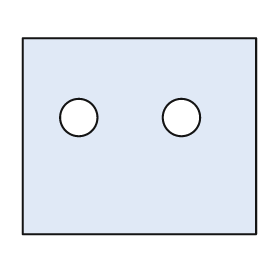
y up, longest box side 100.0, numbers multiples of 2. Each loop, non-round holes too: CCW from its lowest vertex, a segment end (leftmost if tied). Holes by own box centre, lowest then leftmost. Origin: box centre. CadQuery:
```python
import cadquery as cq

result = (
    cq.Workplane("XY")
    .moveTo(-50.0, -42.0)
    .lineTo(50.0, -42.0)
    .lineTo(50.0, 42.0)
    .lineTo(-50.0, 42.0)
    .close()
    .moveTo(-26.0, 8.0)
    .circle(8.0)
    .moveTo(18.0, 8.0)
    .circle(8.0)
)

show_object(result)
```